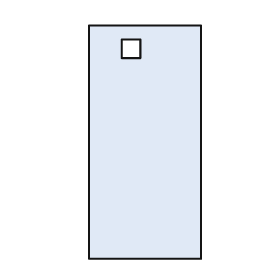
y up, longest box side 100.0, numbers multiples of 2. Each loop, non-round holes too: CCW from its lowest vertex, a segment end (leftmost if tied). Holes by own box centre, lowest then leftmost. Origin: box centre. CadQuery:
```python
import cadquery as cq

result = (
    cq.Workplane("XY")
    .moveTo(-24.0, -50.0)
    .lineTo(24.0, -50.0)
    .lineTo(24.0, 50.0)
    .lineTo(-24.0, 50.0)
    .close()
    .moveTo(-10.0, 36.0)
    .lineTo(-2.0, 36.0)
    .lineTo(-2.0, 44.0)
    .lineTo(-10.0, 44.0)
    .close()
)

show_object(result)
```